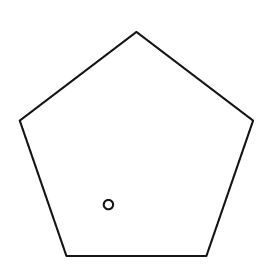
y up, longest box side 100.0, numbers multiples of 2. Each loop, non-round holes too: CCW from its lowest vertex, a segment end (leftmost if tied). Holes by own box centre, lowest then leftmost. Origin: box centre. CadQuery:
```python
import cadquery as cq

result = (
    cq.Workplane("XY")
    .moveTo(-30.0, -48.0)
    .lineTo(30.0, -48.0)
    .lineTo(50.0, 10.0)
    .lineTo(0.0, 48.0)
    .lineTo(-50.0, 10.0)
    .close()
    .moveTo(-12.0, -26.0)
    .circle(2.0)
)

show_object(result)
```